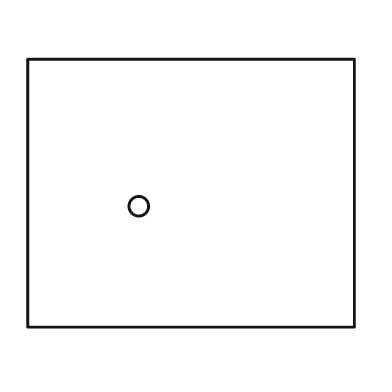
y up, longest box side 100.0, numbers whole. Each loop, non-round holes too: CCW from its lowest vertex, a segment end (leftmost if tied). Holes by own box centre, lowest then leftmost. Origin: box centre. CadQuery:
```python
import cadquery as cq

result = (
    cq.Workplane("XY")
    .moveTo(-50.0, -41.0)
    .lineTo(50.0, -41.0)
    .lineTo(50.0, 41.0)
    .lineTo(-50.0, 41.0)
    .close()
    .moveTo(-16.0, -4.0)
    .circle(3.0)
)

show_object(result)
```